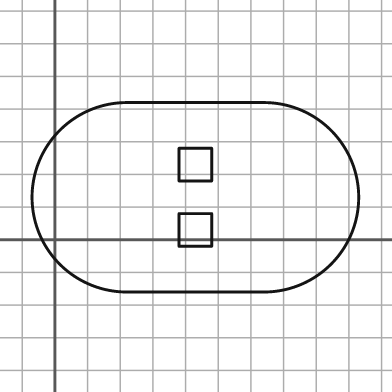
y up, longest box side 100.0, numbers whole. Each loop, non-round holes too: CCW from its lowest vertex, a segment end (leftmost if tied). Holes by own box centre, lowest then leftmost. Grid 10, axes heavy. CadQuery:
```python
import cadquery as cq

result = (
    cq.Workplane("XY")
    .moveTo(22.0, -16.0)
    .lineTo(64.0, -16.0)
    .threePointArc((93.0, 13.0), (64.0, 42.0))
    .lineTo(22.0, 42.0)
    .threePointArc((-7.0, 13.0), (22.0, -16.0))
    .close()
    .moveTo(38.0, -2.0)
    .lineTo(48.0, -2.0)
    .lineTo(48.0, 8.0)
    .lineTo(38.0, 8.0)
    .close()
    .moveTo(38.0, 18.0)
    .lineTo(48.0, 18.0)
    .lineTo(48.0, 28.0)
    .lineTo(38.0, 28.0)
    .close()
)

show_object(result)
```